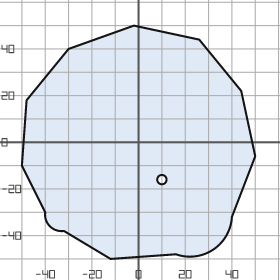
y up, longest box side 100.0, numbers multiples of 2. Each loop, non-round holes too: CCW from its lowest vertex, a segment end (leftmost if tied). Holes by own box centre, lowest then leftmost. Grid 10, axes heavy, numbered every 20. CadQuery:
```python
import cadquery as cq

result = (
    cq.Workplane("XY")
    .moveTo(-12.0, -50.0)
    .lineTo(16.0, -48.0)
    .threePointArc((32.0, -46.0), (40.0, -32.0))
    .lineTo(50.0, -6.0)
    .lineTo(44.0, 22.0)
    .lineTo(26.0, 44.0)
    .lineTo(-2.0, 50.0)
    .lineTo(-30.0, 40.0)
    .lineTo(-48.0, 18.0)
    .lineTo(-50.0, -10.0)
    .lineTo(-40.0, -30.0)
    .threePointArc((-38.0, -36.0), (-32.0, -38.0))
    .close()
    .moveTo(10.0, -16.0)
    .circle(2.0)
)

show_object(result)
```